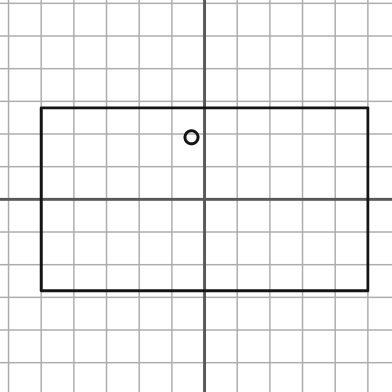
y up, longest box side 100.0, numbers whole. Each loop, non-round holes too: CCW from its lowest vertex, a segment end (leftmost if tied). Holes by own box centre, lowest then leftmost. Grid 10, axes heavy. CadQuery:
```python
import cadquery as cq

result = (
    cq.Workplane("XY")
    .moveTo(-50.0, -28.0)
    .lineTo(50.0, -28.0)
    .lineTo(50.0, 28.0)
    .lineTo(-50.0, 28.0)
    .close()
    .moveTo(-4.0, 19.0)
    .circle(2.0)
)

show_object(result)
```